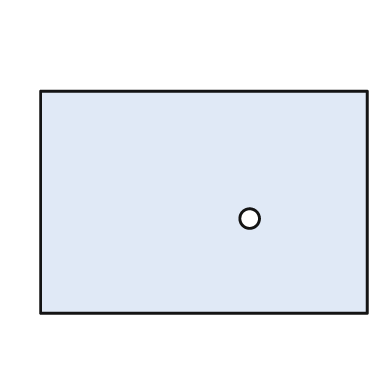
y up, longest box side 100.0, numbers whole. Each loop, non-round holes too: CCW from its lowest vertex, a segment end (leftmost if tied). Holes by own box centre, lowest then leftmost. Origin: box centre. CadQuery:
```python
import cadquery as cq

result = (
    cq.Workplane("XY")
    .moveTo(-50.0, -34.0)
    .lineTo(50.0, -34.0)
    .lineTo(50.0, 34.0)
    .lineTo(-50.0, 34.0)
    .close()
    .moveTo(14.0, -5.0)
    .circle(3.0)
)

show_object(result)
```